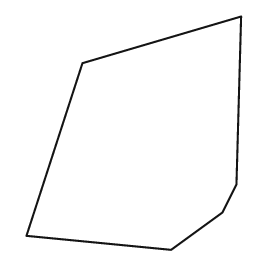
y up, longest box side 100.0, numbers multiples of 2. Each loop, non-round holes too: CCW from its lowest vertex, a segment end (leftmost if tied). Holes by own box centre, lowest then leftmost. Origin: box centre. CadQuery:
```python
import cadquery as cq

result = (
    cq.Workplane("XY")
    .moveTo(16.0, -50.0)
    .lineTo(38.0, -34.0)
    .lineTo(44.0, -22.0)
    .lineTo(46.0, 50.0)
    .lineTo(-22.0, 30.0)
    .lineTo(-46.0, -44.0)
    .close()
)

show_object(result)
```